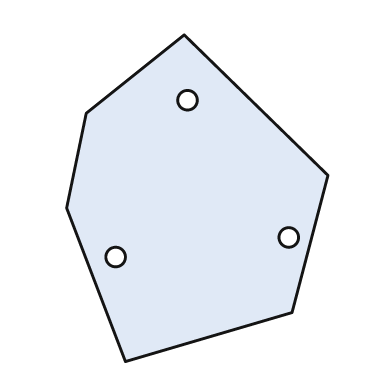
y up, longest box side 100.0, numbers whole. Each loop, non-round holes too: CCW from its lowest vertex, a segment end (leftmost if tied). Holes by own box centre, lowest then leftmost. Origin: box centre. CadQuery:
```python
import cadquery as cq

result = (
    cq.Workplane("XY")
    .moveTo(-22.0, -50.0)
    .lineTo(29.0, -35.0)
    .lineTo(40.0, 7.0)
    .lineTo(-4.0, 50.0)
    .lineTo(-34.0, 26.0)
    .lineTo(-40.0, -3.0)
    .close()
    .moveTo(-25.0, -18.0)
    .circle(3.0)
    .moveTo(28.0, -12.0)
    .circle(3.0)
    .moveTo(-3.0, 30.0)
    .circle(3.0)
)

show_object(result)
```